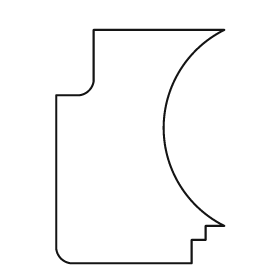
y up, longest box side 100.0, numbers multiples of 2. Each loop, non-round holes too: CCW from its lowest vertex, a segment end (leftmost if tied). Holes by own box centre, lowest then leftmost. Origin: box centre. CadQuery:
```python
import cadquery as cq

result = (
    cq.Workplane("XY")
    .moveTo(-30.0, -50.0)
    .lineTo(22.0, -50.0)
    .lineTo(22.0, -40.0)
    .lineTo(28.0, -40.0)
    .lineTo(28.0, -34.0)
    .lineTo(36.0, -34.0)
    .threePointArc((10.0, 8.0), (36.0, 50.0))
    .lineTo(-20.0, 50.0)
    .lineTo(-20.0, 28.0)
    .threePointArc((-22.0, 24.0), (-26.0, 22.0))
    .lineTo(-36.0, 22.0)
    .lineTo(-36.0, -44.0)
    .threePointArc((-34.0, -48.0), (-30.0, -50.0))
    .close()
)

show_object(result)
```